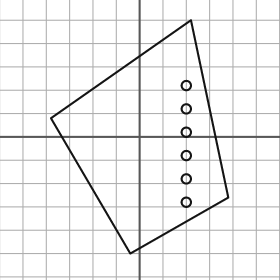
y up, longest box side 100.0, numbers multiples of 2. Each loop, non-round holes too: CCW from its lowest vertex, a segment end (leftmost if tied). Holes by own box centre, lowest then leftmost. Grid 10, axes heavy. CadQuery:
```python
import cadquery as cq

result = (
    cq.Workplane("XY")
    .moveTo(-4.0, -50.0)
    .lineTo(38.0, -26.0)
    .lineTo(22.0, 50.0)
    .lineTo(-38.0, 8.0)
    .close()
    .moveTo(20.0, -28.0)
    .circle(2.0)
    .moveTo(20.0, -18.0)
    .circle(2.0)
    .moveTo(20.0, -8.0)
    .circle(2.0)
    .moveTo(20.0, 2.0)
    .circle(2.0)
    .moveTo(20.0, 12.0)
    .circle(2.0)
    .moveTo(20.0, 22.0)
    .circle(2.0)
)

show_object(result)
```